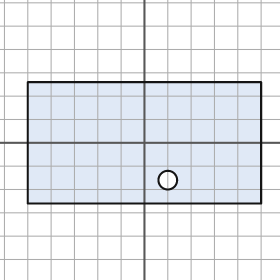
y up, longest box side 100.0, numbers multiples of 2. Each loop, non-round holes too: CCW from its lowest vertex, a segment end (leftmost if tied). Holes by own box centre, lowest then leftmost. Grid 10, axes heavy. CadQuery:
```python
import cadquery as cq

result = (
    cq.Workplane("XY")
    .moveTo(-50.0, -26.0)
    .lineTo(50.0, -26.0)
    .lineTo(50.0, 26.0)
    .lineTo(-50.0, 26.0)
    .close()
    .moveTo(10.0, -16.0)
    .circle(4.0)
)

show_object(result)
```